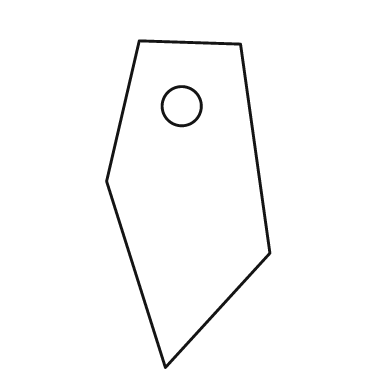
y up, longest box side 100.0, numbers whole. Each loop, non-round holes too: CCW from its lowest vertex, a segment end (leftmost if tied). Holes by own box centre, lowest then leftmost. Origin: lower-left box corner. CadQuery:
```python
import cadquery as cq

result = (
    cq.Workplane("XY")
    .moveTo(18.0, 0.0)
    .lineTo(50.0, 35.0)
    .lineTo(41.0, 99.0)
    .lineTo(10.0, 100.0)
    .lineTo(0.0, 57.0)
    .close()
    .moveTo(23.0, 80.0)
    .circle(6.0)
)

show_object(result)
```